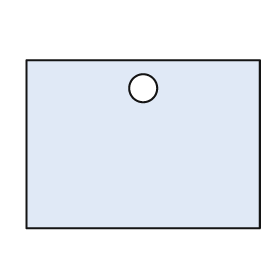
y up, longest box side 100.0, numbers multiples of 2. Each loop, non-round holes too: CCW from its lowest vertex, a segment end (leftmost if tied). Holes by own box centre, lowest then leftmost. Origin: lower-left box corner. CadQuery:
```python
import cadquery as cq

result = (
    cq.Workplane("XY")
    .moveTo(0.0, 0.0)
    .lineTo(100.0, 0.0)
    .lineTo(100.0, 72.0)
    .lineTo(0.0, 72.0)
    .close()
    .moveTo(50.0, 60.0)
    .circle(6.0)
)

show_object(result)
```